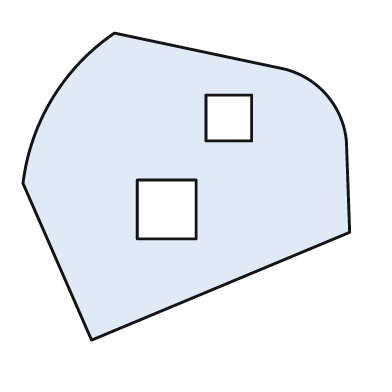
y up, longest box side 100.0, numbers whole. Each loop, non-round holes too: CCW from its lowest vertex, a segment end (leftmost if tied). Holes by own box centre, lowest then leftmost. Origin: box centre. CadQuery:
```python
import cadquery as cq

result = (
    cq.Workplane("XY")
    .moveTo(-29.0, -47.0)
    .lineTo(50.0, -14.0)
    .lineTo(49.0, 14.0)
    .threePointArc((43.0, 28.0), (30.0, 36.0))
    .lineTo(-22.0, 47.0)
    .threePointArc((-41.0, 27.0), (-50.0, 1.0))
    .close()
    .moveTo(-15.0, -16.0)
    .lineTo(3.0, -16.0)
    .lineTo(3.0, 2.0)
    .lineTo(-15.0, 2.0)
    .close()
    .moveTo(6.0, 14.0)
    .lineTo(20.0, 14.0)
    .lineTo(20.0, 28.0)
    .lineTo(6.0, 28.0)
    .close()
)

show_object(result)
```